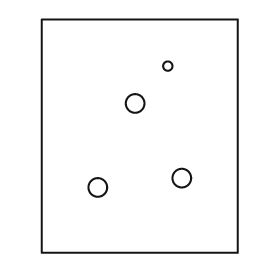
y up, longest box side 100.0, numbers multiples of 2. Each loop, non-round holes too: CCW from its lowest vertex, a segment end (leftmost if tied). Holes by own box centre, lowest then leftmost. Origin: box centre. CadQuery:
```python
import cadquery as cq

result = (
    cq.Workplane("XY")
    .moveTo(-42.0, -50.0)
    .lineTo(42.0, -50.0)
    .lineTo(42.0, 50.0)
    .lineTo(-42.0, 50.0)
    .close()
    .moveTo(-18.0, -22.0)
    .circle(4.0)
    .moveTo(18.0, -18.0)
    .circle(4.0)
    .moveTo(-2.0, 14.0)
    .circle(4.0)
    .moveTo(12.0, 30.0)
    .circle(2.0)
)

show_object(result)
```